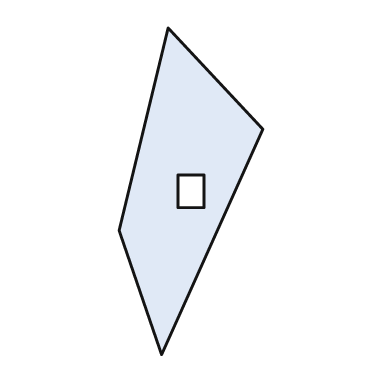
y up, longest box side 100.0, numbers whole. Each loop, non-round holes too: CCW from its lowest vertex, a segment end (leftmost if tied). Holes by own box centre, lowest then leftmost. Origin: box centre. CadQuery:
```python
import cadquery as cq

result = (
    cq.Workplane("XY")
    .moveTo(-9.0, -50.0)
    .lineTo(22.0, 19.0)
    .lineTo(-7.0, 50.0)
    .lineTo(-22.0, -12.0)
    .close()
    .moveTo(-4.0, -5.0)
    .lineTo(4.0, -5.0)
    .lineTo(4.0, 5.0)
    .lineTo(-4.0, 5.0)
    .close()
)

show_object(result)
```